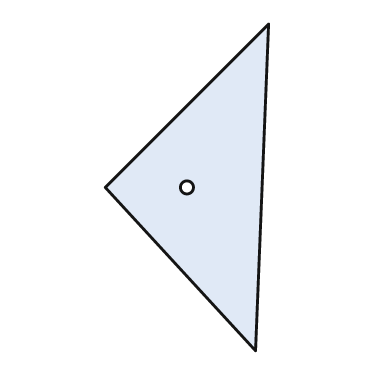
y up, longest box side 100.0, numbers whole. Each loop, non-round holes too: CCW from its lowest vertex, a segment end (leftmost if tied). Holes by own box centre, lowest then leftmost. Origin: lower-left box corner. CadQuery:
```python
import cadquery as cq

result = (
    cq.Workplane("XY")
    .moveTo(46.0, 0.0)
    .lineTo(50.0, 100.0)
    .lineTo(0.0, 50.0)
    .close()
    .moveTo(25.0, 50.0)
    .circle(2.0)
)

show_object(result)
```